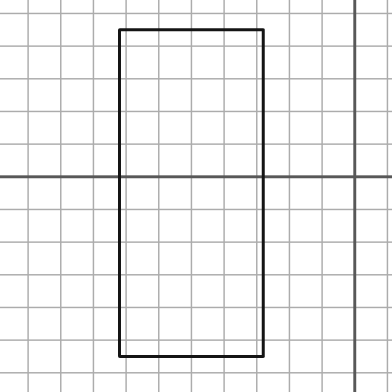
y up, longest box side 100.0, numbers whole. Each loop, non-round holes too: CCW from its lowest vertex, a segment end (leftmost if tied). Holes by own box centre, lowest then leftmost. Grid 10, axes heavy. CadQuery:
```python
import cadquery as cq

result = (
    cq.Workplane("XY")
    .moveTo(-72.0, -55.0)
    .lineTo(-28.0, -55.0)
    .lineTo(-28.0, 45.0)
    .lineTo(-72.0, 45.0)
    .close()
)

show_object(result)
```